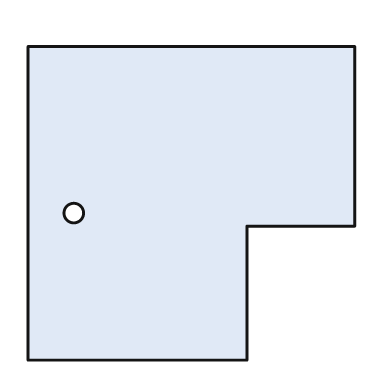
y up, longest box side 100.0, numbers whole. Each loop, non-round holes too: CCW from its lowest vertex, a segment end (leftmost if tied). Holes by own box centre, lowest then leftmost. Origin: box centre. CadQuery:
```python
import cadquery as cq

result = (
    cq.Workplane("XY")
    .moveTo(-50.0, -48.0)
    .lineTo(17.0, -48.0)
    .lineTo(17.0, -7.0)
    .lineTo(50.0, -7.0)
    .lineTo(50.0, 48.0)
    .lineTo(-50.0, 48.0)
    .close()
    .moveTo(-36.0, -3.0)
    .circle(3.0)
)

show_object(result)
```